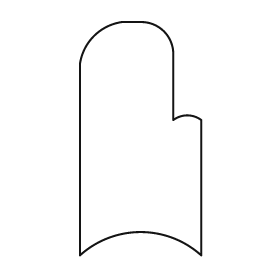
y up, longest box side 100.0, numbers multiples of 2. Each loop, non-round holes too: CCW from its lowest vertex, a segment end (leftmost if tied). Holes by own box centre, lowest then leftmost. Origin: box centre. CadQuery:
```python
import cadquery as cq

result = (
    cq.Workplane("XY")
    .moveTo(-26.0, -50.0)
    .threePointArc((0.0, -40.0), (26.0, -50.0))
    .lineTo(26.0, 8.0)
    .threePointArc((20.0, 10.0), (14.0, 8.0))
    .lineTo(14.0, 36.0)
    .threePointArc((10.0, 46.0), (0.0, 50.0))
    .lineTo(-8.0, 50.0)
    .threePointArc((-20.0, 44.0), (-26.0, 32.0))
    .close()
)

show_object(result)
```